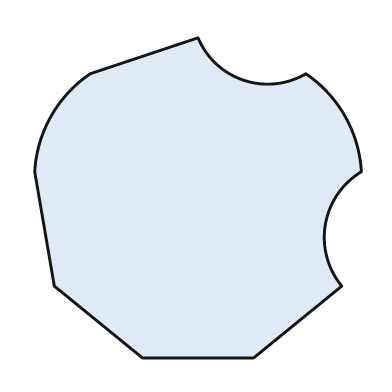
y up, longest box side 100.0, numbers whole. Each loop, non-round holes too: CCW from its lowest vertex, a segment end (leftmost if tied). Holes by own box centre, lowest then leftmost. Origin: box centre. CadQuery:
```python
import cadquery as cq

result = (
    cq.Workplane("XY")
    .moveTo(-17.0, -49.0)
    .lineTo(17.0, -49.0)
    .lineTo(44.0, -27.0)
    .threePointArc((39.0, -8.0), (50.0, 8.0))
    .threePointArc((45.0, 25.0), (33.0, 38.0))
    .threePointArc((14.0, 36.0), (0.0, 49.0))
    .lineTo(-33.0, 38.0)
    .threePointArc((-45.0, 25.0), (-50.0, 8.0))
    .lineTo(-44.0, -27.0)
    .close()
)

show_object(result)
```